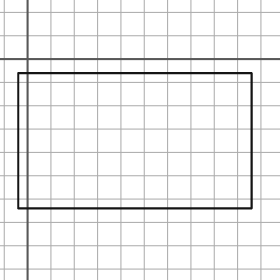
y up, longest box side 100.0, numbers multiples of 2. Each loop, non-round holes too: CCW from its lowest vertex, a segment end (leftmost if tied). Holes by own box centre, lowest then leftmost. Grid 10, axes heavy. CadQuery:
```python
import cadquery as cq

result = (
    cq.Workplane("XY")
    .moveTo(-4.0, -64.0)
    .lineTo(96.0, -64.0)
    .lineTo(96.0, -6.0)
    .lineTo(-4.0, -6.0)
    .close()
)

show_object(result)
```